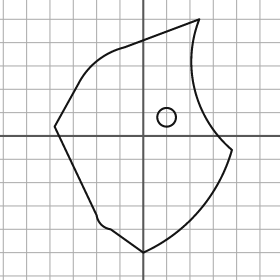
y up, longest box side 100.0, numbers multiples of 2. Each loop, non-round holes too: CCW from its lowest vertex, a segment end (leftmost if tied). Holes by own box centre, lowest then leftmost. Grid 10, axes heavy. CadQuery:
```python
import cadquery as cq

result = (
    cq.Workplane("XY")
    .moveTo(0.0, -50.0)
    .threePointArc((24.0, -32.0), (38.0, -6.0))
    .threePointArc((22.0, 20.0), (24.0, 50.0))
    .lineTo(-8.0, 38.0)
    .threePointArc((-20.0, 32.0), (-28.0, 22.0))
    .lineTo(-38.0, 4.0)
    .lineTo(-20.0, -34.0)
    .threePointArc((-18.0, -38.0), (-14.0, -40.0))
    .close()
    .moveTo(10.0, 8.0)
    .circle(4.0)
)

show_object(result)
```